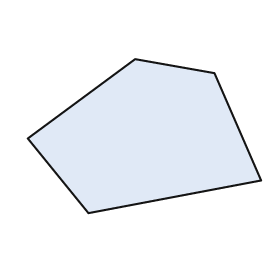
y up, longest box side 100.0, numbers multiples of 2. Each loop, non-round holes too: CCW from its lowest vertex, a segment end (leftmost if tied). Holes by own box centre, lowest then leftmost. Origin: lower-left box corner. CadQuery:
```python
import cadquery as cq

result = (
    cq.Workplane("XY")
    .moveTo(26.0, 0.0)
    .lineTo(100.0, 14.0)
    .lineTo(80.0, 60.0)
    .lineTo(46.0, 66.0)
    .lineTo(0.0, 32.0)
    .close()
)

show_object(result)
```